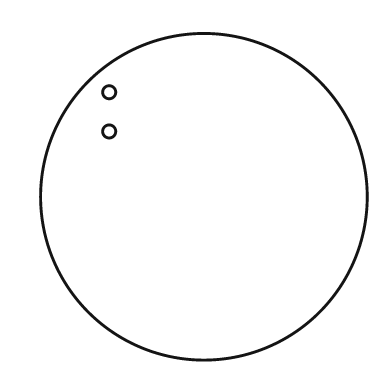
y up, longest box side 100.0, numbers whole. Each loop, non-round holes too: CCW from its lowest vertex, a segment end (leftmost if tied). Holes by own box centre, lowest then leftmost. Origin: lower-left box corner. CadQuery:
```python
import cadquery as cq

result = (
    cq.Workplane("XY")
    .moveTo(50.0, 50.0)
    .circle(50.0)
    .moveTo(21.0, 70.0)
    .circle(2.0)
    .moveTo(21.0, 82.0)
    .circle(2.0)
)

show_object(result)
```